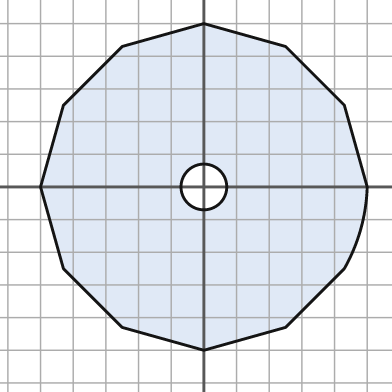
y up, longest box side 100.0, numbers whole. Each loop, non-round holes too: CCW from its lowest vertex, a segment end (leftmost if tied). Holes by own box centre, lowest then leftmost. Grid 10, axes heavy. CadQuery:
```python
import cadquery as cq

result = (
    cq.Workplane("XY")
    .moveTo(0.0, -50.0)
    .lineTo(25.0, -43.0)
    .lineTo(43.0, -25.0)
    .threePointArc((48.0, -13.0), (50.0, 0.0))
    .lineTo(43.0, 25.0)
    .lineTo(25.0, 43.0)
    .lineTo(0.0, 50.0)
    .lineTo(-25.0, 43.0)
    .lineTo(-43.0, 25.0)
    .lineTo(-50.0, 0.0)
    .lineTo(-43.0, -25.0)
    .lineTo(-25.0, -43.0)
    .close()
    .moveTo(0.0, 0.0)
    .circle(7.0)
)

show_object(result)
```